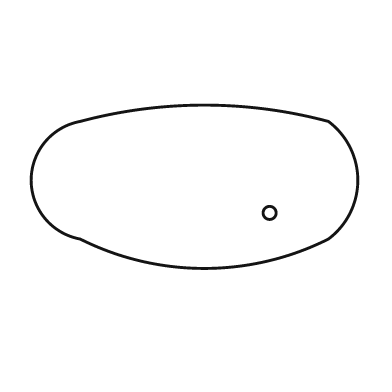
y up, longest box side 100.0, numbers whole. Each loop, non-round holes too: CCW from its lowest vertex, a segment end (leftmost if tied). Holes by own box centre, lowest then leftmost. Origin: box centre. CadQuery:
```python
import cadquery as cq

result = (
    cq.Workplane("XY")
    .moveTo(-35.0, -16.0)
    .threePointArc((3.0, -25.0), (41.0, -16.0))
    .threePointArc((50.0, 2.0), (41.0, 20.0))
    .threePointArc((3.0, 25.0), (-35.0, 20.0))
    .threePointArc((-50.0, 2.0), (-35.0, -16.0))
    .close()
    .moveTo(23.0, -8.0)
    .circle(2.0)
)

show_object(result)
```